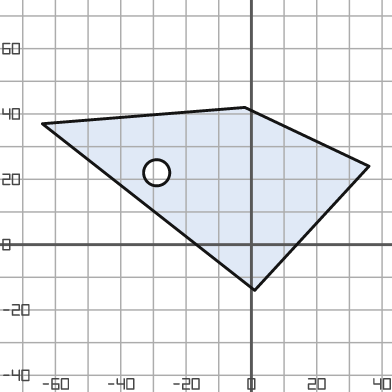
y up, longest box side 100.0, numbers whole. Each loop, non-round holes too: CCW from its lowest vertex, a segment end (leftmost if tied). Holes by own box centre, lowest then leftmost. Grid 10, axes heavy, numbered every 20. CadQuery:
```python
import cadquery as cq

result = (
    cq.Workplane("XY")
    .moveTo(1.0, -14.0)
    .lineTo(36.0, 24.0)
    .lineTo(-2.0, 42.0)
    .lineTo(-64.0, 37.0)
    .close()
    .moveTo(-29.0, 22.0)
    .circle(4.0)
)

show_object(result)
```